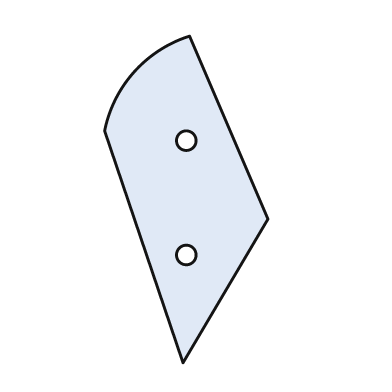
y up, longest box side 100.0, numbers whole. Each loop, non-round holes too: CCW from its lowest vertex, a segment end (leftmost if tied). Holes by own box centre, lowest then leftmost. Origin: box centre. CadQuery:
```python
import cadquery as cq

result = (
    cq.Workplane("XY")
    .moveTo(-1.0, -50.0)
    .lineTo(25.0, -6.0)
    .lineTo(1.0, 50.0)
    .threePointArc((-16.0, 39.0), (-25.0, 21.0))
    .close()
    .moveTo(0.0, -17.0)
    .circle(3.0)
    .moveTo(0.0, 18.0)
    .circle(3.0)
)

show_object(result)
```